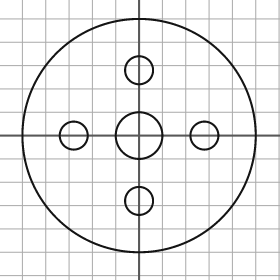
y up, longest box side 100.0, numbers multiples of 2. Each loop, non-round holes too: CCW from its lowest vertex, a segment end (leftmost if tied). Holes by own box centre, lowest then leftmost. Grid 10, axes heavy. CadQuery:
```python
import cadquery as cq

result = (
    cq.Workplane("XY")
    .moveTo(0.0, 0.0)
    .circle(50.0)
    .moveTo(0.0, -28.0)
    .circle(6.0)
    .moveTo(-28.0, 0.0)
    .circle(6.0)
    .moveTo(0.0, 0.0)
    .circle(10.0)
    .moveTo(28.0, 0.0)
    .circle(6.0)
    .moveTo(0.0, 28.0)
    .circle(6.0)
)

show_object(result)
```